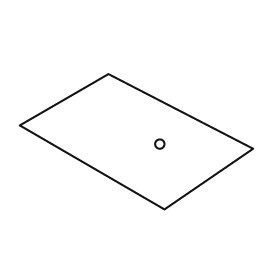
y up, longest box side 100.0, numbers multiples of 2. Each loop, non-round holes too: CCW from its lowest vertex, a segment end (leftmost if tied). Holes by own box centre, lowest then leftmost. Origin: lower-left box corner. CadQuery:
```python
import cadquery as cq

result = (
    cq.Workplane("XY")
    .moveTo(62.0, 0.0)
    .lineTo(100.0, 26.0)
    .lineTo(38.0, 58.0)
    .lineTo(0.0, 36.0)
    .close()
    .moveTo(60.0, 28.0)
    .circle(2.0)
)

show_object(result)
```